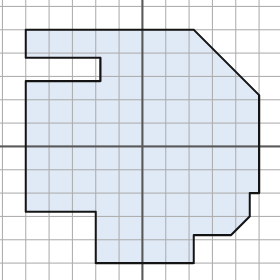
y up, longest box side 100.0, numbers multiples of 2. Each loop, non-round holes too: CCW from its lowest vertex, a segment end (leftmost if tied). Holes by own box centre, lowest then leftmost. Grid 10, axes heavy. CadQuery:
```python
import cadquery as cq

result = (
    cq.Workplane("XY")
    .moveTo(-20.0, -50.0)
    .lineTo(22.0, -50.0)
    .lineTo(22.0, -38.0)
    .lineTo(38.0, -38.0)
    .lineTo(46.0, -30.0)
    .lineTo(46.0, -20.0)
    .lineTo(50.0, -20.0)
    .lineTo(50.0, 22.0)
    .lineTo(22.0, 50.0)
    .lineTo(-50.0, 50.0)
    .lineTo(-50.0, 38.0)
    .lineTo(-18.0, 38.0)
    .lineTo(-18.0, 28.0)
    .lineTo(-50.0, 28.0)
    .lineTo(-50.0, -28.0)
    .lineTo(-20.0, -28.0)
    .close()
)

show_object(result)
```